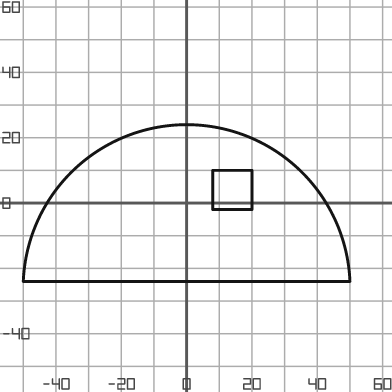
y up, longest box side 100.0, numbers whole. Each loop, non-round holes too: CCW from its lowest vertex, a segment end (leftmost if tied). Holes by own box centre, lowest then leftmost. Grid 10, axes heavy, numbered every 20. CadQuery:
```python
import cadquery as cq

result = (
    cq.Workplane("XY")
    .moveTo(-50.0, -24.0)
    .lineTo(50.0, -24.0)
    .threePointArc((0.0, 24.0), (-50.0, -24.0))
    .close()
    .moveTo(8.0, -2.0)
    .lineTo(20.0, -2.0)
    .lineTo(20.0, 10.0)
    .lineTo(8.0, 10.0)
    .close()
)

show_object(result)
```